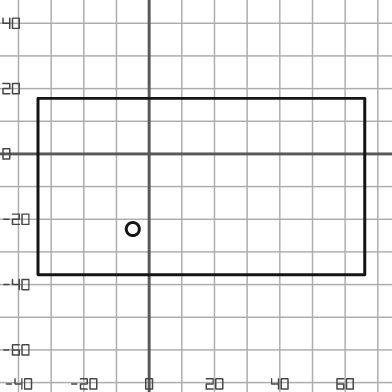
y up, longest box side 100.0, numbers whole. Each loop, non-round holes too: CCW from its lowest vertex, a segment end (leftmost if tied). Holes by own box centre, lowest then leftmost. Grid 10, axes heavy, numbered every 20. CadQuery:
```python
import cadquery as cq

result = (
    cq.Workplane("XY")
    .moveTo(-34.0, -37.0)
    .lineTo(66.0, -37.0)
    .lineTo(66.0, 17.0)
    .lineTo(-34.0, 17.0)
    .close()
    .moveTo(-5.0, -23.0)
    .circle(2.0)
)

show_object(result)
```